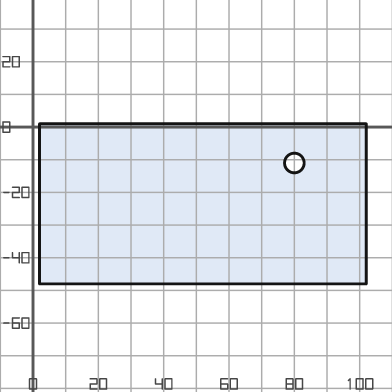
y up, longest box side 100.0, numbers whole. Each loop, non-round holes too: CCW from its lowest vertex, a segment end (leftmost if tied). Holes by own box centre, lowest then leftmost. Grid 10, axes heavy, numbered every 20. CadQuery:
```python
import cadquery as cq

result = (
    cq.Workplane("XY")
    .moveTo(2.0, -48.0)
    .lineTo(102.0, -48.0)
    .lineTo(102.0, 1.0)
    .lineTo(2.0, 1.0)
    .close()
    .moveTo(80.0, -11.0)
    .circle(3.0)
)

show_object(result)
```